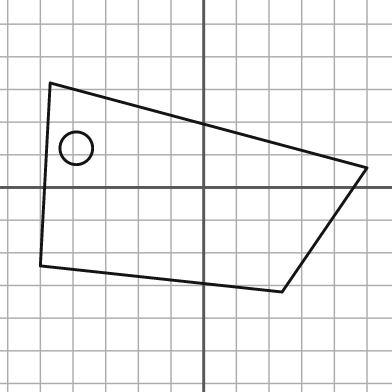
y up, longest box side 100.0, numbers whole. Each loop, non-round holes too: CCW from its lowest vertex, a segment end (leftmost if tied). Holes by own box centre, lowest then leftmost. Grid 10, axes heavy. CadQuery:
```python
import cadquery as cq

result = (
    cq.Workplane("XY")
    .moveTo(24.0, -32.0)
    .lineTo(50.0, 6.0)
    .lineTo(-47.0, 32.0)
    .lineTo(-50.0, -24.0)
    .close()
    .moveTo(-39.0, 12.0)
    .circle(5.0)
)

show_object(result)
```